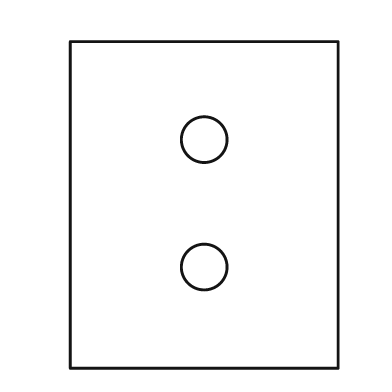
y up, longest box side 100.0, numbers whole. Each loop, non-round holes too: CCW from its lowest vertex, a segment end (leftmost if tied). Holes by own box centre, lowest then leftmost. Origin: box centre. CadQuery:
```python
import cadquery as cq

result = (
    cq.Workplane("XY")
    .moveTo(-41.0, -50.0)
    .lineTo(41.0, -50.0)
    .lineTo(41.0, 50.0)
    .lineTo(-41.0, 50.0)
    .close()
    .moveTo(0.0, -19.0)
    .circle(7.0)
    .moveTo(0.0, 20.0)
    .circle(7.0)
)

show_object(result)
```